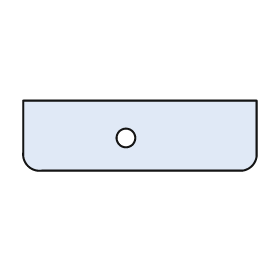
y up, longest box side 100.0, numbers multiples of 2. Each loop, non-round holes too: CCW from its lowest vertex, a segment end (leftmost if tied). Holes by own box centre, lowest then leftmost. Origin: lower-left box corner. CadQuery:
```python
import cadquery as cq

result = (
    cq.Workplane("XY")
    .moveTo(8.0, 0.0)
    .lineTo(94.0, 0.0)
    .threePointArc((98.0, 2.0), (100.0, 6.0))
    .lineTo(100.0, 30.0)
    .lineTo(0.0, 30.0)
    .lineTo(0.0, 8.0)
    .threePointArc((2.0, 2.0), (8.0, 0.0))
    .close()
    .moveTo(44.0, 14.0)
    .circle(4.0)
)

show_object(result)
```